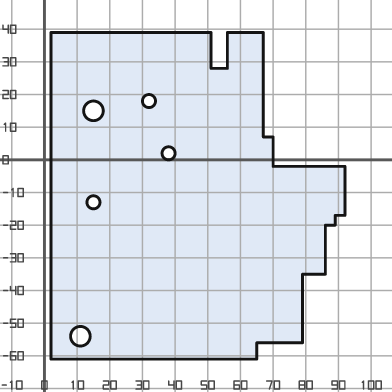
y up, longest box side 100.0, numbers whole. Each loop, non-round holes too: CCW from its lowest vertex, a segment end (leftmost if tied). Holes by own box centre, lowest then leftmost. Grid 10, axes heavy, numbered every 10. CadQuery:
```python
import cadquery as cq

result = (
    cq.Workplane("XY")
    .moveTo(2.0, -61.0)
    .lineTo(65.0, -61.0)
    .lineTo(65.0, -56.0)
    .lineTo(79.0, -56.0)
    .lineTo(79.0, -35.0)
    .lineTo(86.0, -35.0)
    .lineTo(86.0, -20.0)
    .lineTo(89.0, -20.0)
    .lineTo(89.0, -17.0)
    .lineTo(92.0, -17.0)
    .lineTo(92.0, -2.0)
    .lineTo(70.0, -2.0)
    .lineTo(70.0, 7.0)
    .lineTo(67.0, 7.0)
    .lineTo(67.0, 39.0)
    .lineTo(56.0, 39.0)
    .lineTo(56.0, 28.0)
    .lineTo(51.0, 28.0)
    .lineTo(51.0, 39.0)
    .lineTo(2.0, 39.0)
    .close()
    .moveTo(11.0, -54.0)
    .circle(3.0)
    .moveTo(15.0, -13.0)
    .circle(2.0)
    .moveTo(38.0, 2.0)
    .circle(2.0)
    .moveTo(15.0, 15.0)
    .circle(3.0)
    .moveTo(32.0, 18.0)
    .circle(2.0)
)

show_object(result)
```